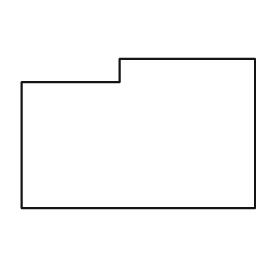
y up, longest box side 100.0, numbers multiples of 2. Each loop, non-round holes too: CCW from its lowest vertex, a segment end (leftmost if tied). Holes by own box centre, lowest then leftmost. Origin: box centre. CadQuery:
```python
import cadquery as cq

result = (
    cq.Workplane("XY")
    .moveTo(-50.0, -32.0)
    .lineTo(50.0, -32.0)
    .lineTo(50.0, 32.0)
    .lineTo(-8.0, 32.0)
    .lineTo(-8.0, 22.0)
    .lineTo(-50.0, 22.0)
    .close()
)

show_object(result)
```